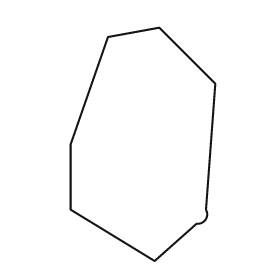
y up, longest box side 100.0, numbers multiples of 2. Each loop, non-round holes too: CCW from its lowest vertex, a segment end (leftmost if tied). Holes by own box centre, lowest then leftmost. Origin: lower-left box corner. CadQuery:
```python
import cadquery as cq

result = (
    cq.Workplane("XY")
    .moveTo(36.0, 0.0)
    .lineTo(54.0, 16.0)
    .threePointArc((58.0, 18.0), (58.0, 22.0))
    .lineTo(62.0, 76.0)
    .lineTo(38.0, 100.0)
    .lineTo(16.0, 96.0)
    .lineTo(0.0, 50.0)
    .lineTo(0.0, 22.0)
    .close()
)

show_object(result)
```